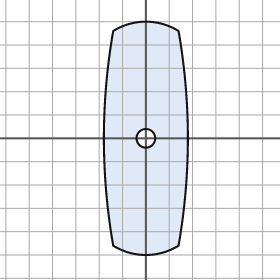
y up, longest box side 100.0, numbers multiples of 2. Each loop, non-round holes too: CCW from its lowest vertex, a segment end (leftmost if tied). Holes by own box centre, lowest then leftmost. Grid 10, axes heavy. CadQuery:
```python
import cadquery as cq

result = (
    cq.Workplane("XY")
    .moveTo(-14.0, -46.0)
    .threePointArc((0.0, -50.0), (14.0, -46.0))
    .threePointArc((18.0, 0.0), (14.0, 46.0))
    .threePointArc((0.0, 50.0), (-14.0, 46.0))
    .threePointArc((-18.0, 0.0), (-14.0, -46.0))
    .close()
    .moveTo(0.0, 0.0)
    .circle(4.0)
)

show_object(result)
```